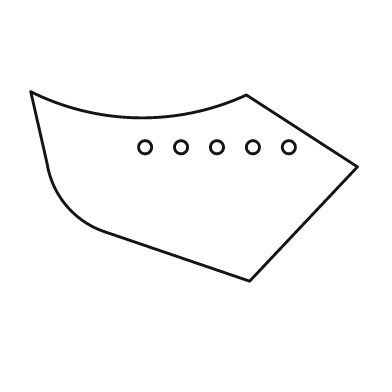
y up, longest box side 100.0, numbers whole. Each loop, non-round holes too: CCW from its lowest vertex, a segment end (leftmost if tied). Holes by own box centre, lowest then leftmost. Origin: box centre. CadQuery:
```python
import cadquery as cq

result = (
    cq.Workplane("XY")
    .moveTo(17.0, -29.0)
    .lineTo(50.0, 6.0)
    .lineTo(16.0, 28.0)
    .threePointArc((-17.0, 21.0), (-50.0, 29.0))
    .lineTo(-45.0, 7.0)
    .threePointArc((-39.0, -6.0), (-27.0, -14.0))
    .close()
    .moveTo(-15.0, 12.0)
    .circle(2.0)
    .moveTo(-4.0, 12.0)
    .circle(2.0)
    .moveTo(7.0, 12.0)
    .circle(2.0)
    .moveTo(18.0, 12.0)
    .circle(2.0)
    .moveTo(29.0, 12.0)
    .circle(2.0)
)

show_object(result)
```